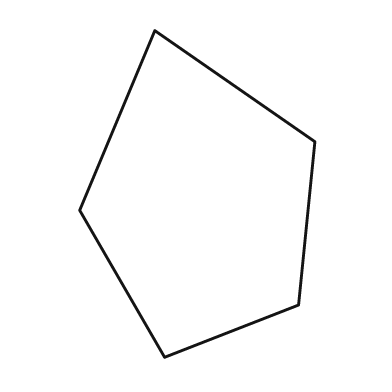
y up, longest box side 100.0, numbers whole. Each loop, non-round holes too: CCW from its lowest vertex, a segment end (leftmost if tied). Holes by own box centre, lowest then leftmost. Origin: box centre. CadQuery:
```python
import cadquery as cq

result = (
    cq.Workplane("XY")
    .moveTo(-10.0, -50.0)
    .lineTo(31.0, -34.0)
    .lineTo(36.0, 16.0)
    .lineTo(-13.0, 50.0)
    .lineTo(-36.0, -5.0)
    .close()
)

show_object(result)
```